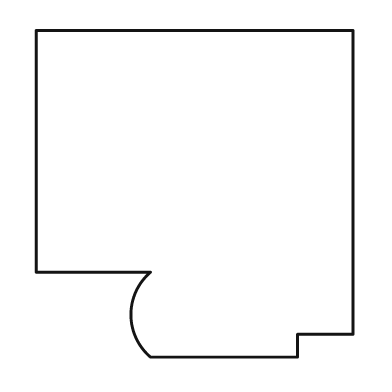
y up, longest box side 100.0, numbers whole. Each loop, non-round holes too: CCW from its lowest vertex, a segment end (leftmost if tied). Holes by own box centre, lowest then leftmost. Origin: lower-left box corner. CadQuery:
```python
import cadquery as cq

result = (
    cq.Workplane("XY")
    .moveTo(35.0, 0.0)
    .lineTo(80.0, 0.0)
    .lineTo(80.0, 7.0)
    .lineTo(97.0, 7.0)
    .lineTo(97.0, 100.0)
    .lineTo(0.0, 100.0)
    .lineTo(0.0, 26.0)
    .lineTo(35.0, 26.0)
    .threePointArc((29.0, 13.0), (35.0, 0.0))
    .close()
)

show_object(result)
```